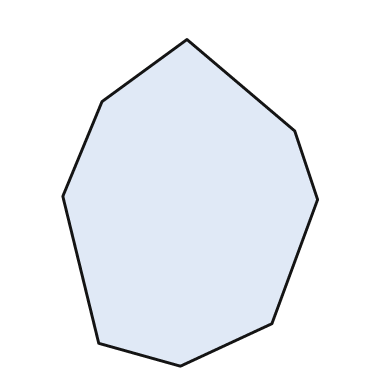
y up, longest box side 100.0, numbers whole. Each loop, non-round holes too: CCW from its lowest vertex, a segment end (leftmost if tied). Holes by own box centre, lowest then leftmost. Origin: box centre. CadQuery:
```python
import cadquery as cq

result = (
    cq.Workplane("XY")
    .moveTo(-3.0, -50.0)
    .lineTo(25.0, -37.0)
    .lineTo(39.0, 1.0)
    .lineTo(32.0, 22.0)
    .lineTo(-1.0, 50.0)
    .lineTo(-27.0, 31.0)
    .lineTo(-39.0, 2.0)
    .lineTo(-28.0, -43.0)
    .close()
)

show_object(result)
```